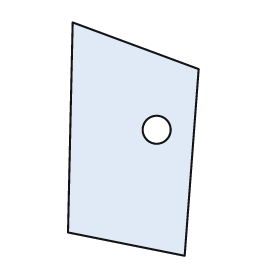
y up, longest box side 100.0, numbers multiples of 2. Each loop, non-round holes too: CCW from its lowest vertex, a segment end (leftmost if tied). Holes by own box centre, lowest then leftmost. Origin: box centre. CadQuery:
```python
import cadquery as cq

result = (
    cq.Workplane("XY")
    .moveTo(22.0, -50.0)
    .lineTo(28.0, 30.0)
    .lineTo(-26.0, 50.0)
    .lineTo(-28.0, -40.0)
    .close()
    .moveTo(10.0, 4.0)
    .circle(6.0)
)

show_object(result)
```